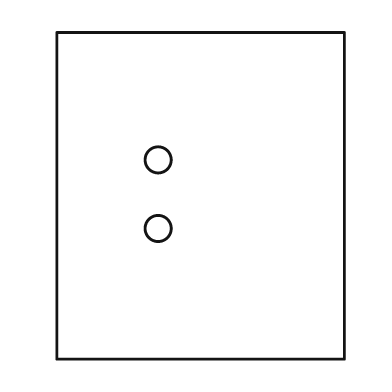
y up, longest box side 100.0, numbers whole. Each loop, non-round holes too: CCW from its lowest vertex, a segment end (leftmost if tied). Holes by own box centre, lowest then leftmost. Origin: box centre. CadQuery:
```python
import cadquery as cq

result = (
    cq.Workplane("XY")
    .moveTo(-44.0, -50.0)
    .lineTo(44.0, -50.0)
    .lineTo(44.0, 50.0)
    .lineTo(-44.0, 50.0)
    .close()
    .moveTo(-13.0, -10.0)
    .circle(4.0)
    .moveTo(-13.0, 11.0)
    .circle(4.0)
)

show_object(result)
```